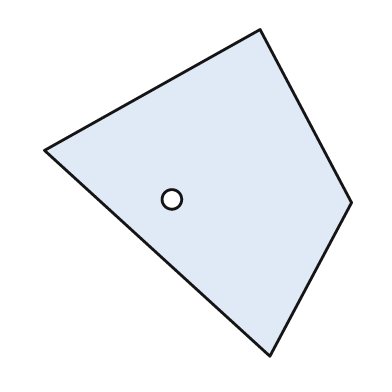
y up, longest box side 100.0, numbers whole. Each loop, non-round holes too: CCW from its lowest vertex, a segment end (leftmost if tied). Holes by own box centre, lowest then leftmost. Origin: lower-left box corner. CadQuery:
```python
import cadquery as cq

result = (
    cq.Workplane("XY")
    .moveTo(69.0, 0.0)
    .lineTo(94.0, 47.0)
    .lineTo(66.0, 100.0)
    .lineTo(0.0, 63.0)
    .close()
    .moveTo(39.0, 48.0)
    .circle(3.0)
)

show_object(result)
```